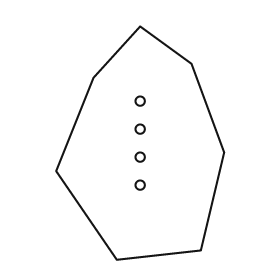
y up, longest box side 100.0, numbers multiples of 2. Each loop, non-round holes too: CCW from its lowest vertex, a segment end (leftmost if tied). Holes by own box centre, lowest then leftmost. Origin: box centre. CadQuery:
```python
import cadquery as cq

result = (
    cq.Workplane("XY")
    .moveTo(-10.0, -50.0)
    .lineTo(26.0, -46.0)
    .lineTo(36.0, -4.0)
    .lineTo(22.0, 34.0)
    .lineTo(0.0, 50.0)
    .lineTo(-20.0, 28.0)
    .lineTo(-36.0, -12.0)
    .close()
    .moveTo(0.0, -18.0)
    .circle(2.0)
    .moveTo(0.0, -6.0)
    .circle(2.0)
    .moveTo(0.0, 6.0)
    .circle(2.0)
    .moveTo(0.0, 18.0)
    .circle(2.0)
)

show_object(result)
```